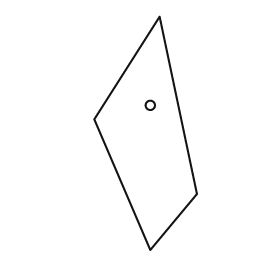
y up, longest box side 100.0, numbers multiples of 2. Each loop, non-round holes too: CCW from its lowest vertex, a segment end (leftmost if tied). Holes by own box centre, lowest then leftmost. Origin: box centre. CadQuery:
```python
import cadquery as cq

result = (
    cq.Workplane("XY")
    .moveTo(2.0, -50.0)
    .lineTo(22.0, -26.0)
    .lineTo(6.0, 50.0)
    .lineTo(-22.0, 6.0)
    .close()
    .moveTo(2.0, 12.0)
    .circle(2.0)
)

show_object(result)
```